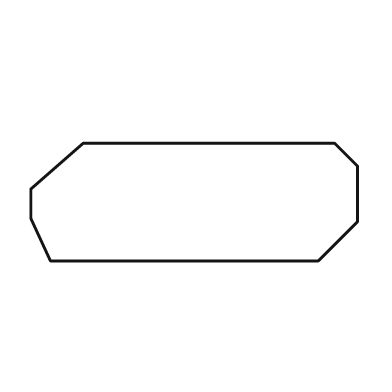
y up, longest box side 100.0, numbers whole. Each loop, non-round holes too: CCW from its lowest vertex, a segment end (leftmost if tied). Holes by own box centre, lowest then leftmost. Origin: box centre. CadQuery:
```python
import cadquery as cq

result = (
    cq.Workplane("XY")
    .moveTo(-44.0, -18.0)
    .lineTo(38.0, -18.0)
    .lineTo(50.0, -6.0)
    .lineTo(50.0, 11.0)
    .lineTo(43.0, 18.0)
    .lineTo(-34.0, 18.0)
    .lineTo(-50.0, 4.0)
    .lineTo(-50.0, -5.0)
    .close()
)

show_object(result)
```